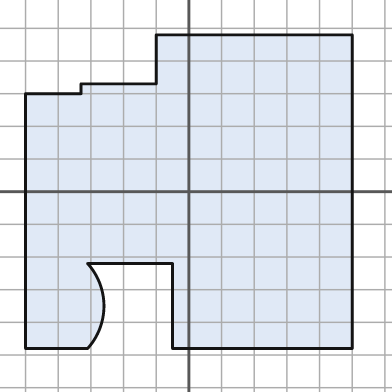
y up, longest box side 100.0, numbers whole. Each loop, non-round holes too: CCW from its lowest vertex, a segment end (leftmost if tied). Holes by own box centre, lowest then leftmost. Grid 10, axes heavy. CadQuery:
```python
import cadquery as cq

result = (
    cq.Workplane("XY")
    .moveTo(-50.0, -48.0)
    .lineTo(-31.0, -48.0)
    .threePointArc((-26.0, -35.0), (-31.0, -22.0))
    .lineTo(-5.0, -22.0)
    .lineTo(-5.0, -48.0)
    .lineTo(50.0, -48.0)
    .lineTo(50.0, 48.0)
    .lineTo(-10.0, 48.0)
    .lineTo(-10.0, 33.0)
    .lineTo(-33.0, 33.0)
    .lineTo(-33.0, 30.0)
    .lineTo(-50.0, 30.0)
    .close()
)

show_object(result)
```